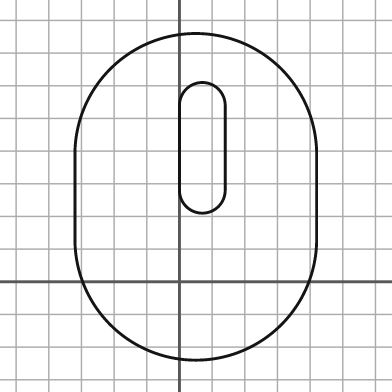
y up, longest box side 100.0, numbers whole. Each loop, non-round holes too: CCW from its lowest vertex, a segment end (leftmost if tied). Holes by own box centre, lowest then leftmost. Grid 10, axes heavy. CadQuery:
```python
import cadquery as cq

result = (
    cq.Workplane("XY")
    .moveTo(-32.0, 13.0)
    .threePointArc((5.0, -24.0), (42.0, 13.0))
    .lineTo(42.0, 39.0)
    .threePointArc((5.0, 76.0), (-32.0, 39.0))
    .close()
    .moveTo(0.0, 28.0)
    .threePointArc((7.0, 21.0), (14.0, 28.0))
    .lineTo(14.0, 54.0)
    .threePointArc((7.0, 61.0), (0.0, 54.0))
    .close()
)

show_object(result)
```